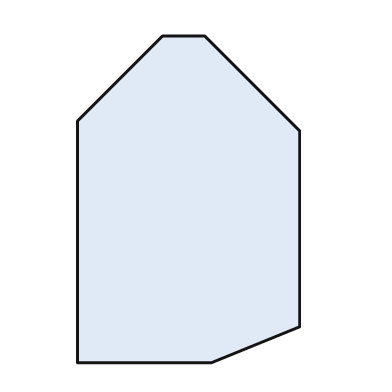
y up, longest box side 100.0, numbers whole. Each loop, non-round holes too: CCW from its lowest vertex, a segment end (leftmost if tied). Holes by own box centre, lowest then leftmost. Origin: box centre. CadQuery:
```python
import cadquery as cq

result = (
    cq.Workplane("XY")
    .moveTo(-34.0, -50.0)
    .lineTo(7.0, -50.0)
    .lineTo(34.0, -39.0)
    .lineTo(34.0, 21.0)
    .lineTo(5.0, 50.0)
    .lineTo(-8.0, 50.0)
    .lineTo(-34.0, 24.0)
    .close()
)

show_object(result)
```